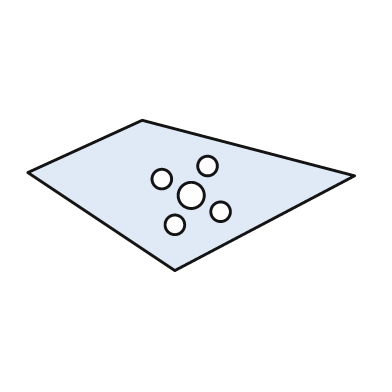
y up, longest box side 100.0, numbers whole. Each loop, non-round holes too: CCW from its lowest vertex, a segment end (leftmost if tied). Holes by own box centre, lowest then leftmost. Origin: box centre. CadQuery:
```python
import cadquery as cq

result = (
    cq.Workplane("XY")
    .moveTo(-5.0, -23.0)
    .lineTo(50.0, 6.0)
    .lineTo(-15.0, 23.0)
    .lineTo(-50.0, 7.0)
    .close()
    .moveTo(-5.0, -9.0)
    .circle(3.0)
    .moveTo(9.0, -5.0)
    .circle(3.0)
    .moveTo(0.0, 0.0)
    .circle(4.0)
    .moveTo(-9.0, 5.0)
    .circle(3.0)
    .moveTo(5.0, 9.0)
    .circle(3.0)
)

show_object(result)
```